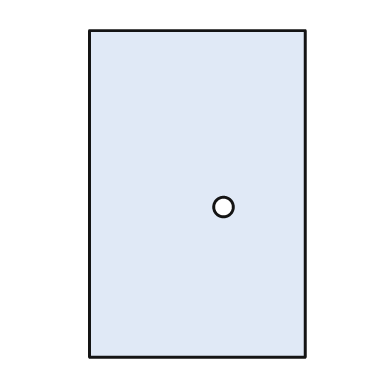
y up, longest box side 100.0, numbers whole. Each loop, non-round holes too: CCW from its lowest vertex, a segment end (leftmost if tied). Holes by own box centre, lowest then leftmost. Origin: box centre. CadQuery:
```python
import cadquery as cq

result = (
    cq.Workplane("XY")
    .moveTo(-33.0, -50.0)
    .lineTo(33.0, -50.0)
    .lineTo(33.0, 50.0)
    .lineTo(-33.0, 50.0)
    .close()
    .moveTo(8.0, -4.0)
    .circle(3.0)
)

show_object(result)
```